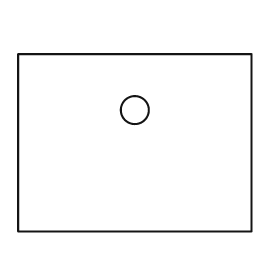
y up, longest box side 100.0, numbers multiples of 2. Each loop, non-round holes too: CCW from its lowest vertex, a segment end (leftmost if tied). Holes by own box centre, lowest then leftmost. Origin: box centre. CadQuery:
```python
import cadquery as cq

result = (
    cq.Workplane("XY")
    .moveTo(-50.0, -38.0)
    .lineTo(50.0, -38.0)
    .lineTo(50.0, 38.0)
    .lineTo(-50.0, 38.0)
    .close()
    .moveTo(0.0, 14.0)
    .circle(6.0)
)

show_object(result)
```